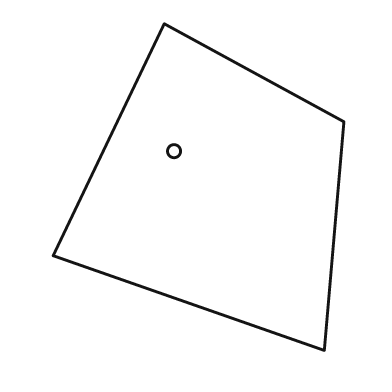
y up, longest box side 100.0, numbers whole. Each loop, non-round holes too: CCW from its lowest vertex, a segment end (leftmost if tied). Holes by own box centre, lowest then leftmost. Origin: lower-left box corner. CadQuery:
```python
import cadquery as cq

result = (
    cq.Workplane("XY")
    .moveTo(83.0, 0.0)
    .lineTo(89.0, 70.0)
    .lineTo(34.0, 100.0)
    .lineTo(0.0, 29.0)
    .close()
    .moveTo(37.0, 61.0)
    .circle(2.0)
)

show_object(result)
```